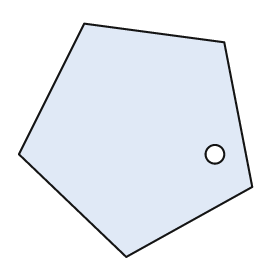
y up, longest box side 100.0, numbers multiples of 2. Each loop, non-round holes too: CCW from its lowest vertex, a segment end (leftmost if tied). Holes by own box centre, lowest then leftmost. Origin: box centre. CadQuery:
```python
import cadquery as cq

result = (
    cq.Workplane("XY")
    .moveTo(-4.0, -50.0)
    .lineTo(50.0, -20.0)
    .lineTo(38.0, 42.0)
    .lineTo(-22.0, 50.0)
    .lineTo(-50.0, -6.0)
    .close()
    .moveTo(34.0, -6.0)
    .circle(4.0)
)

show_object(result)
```